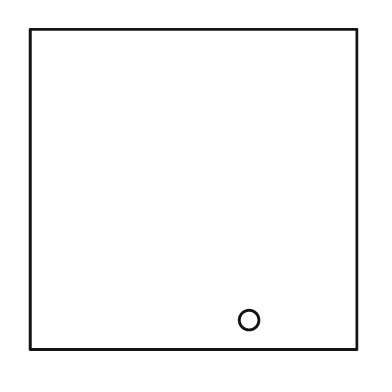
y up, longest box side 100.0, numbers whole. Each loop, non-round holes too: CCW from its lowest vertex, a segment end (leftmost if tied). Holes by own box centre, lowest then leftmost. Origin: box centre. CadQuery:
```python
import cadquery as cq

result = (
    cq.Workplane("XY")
    .moveTo(-50.0, -49.0)
    .lineTo(50.0, -49.0)
    .lineTo(50.0, 49.0)
    .lineTo(-50.0, 49.0)
    .close()
    .moveTo(17.0, -40.0)
    .circle(3.0)
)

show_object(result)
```